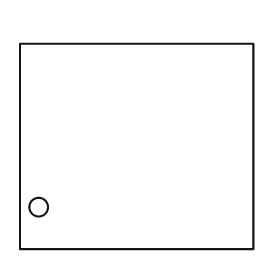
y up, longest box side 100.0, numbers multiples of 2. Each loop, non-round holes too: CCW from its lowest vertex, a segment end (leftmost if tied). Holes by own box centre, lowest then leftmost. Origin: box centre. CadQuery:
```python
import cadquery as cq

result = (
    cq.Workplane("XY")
    .moveTo(-50.0, -44.0)
    .lineTo(50.0, -44.0)
    .lineTo(50.0, 44.0)
    .lineTo(-50.0, 44.0)
    .close()
    .moveTo(-42.0, -26.0)
    .circle(4.0)
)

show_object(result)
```